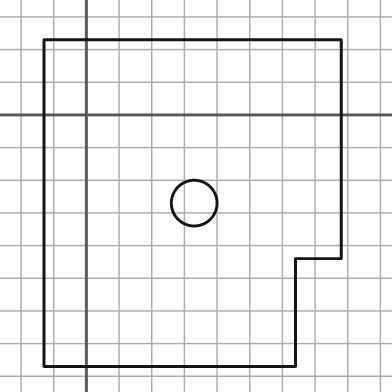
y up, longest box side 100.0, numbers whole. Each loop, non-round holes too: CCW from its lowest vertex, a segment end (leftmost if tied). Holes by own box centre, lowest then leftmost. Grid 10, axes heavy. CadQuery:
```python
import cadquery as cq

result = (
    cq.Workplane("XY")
    .moveTo(-13.0, -77.0)
    .lineTo(64.0, -77.0)
    .lineTo(64.0, -44.0)
    .lineTo(78.0, -44.0)
    .lineTo(78.0, 23.0)
    .lineTo(-13.0, 23.0)
    .close()
    .moveTo(33.0, -27.0)
    .circle(7.0)
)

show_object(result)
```